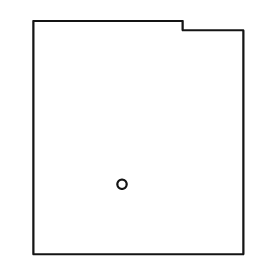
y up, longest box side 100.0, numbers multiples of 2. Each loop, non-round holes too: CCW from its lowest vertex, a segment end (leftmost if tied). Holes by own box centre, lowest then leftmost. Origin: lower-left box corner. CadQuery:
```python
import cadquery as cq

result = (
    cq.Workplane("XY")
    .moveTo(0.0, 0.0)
    .lineTo(90.0, 0.0)
    .lineTo(90.0, 96.0)
    .lineTo(64.0, 96.0)
    .lineTo(64.0, 100.0)
    .lineTo(0.0, 100.0)
    .close()
    .moveTo(38.0, 30.0)
    .circle(2.0)
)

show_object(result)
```